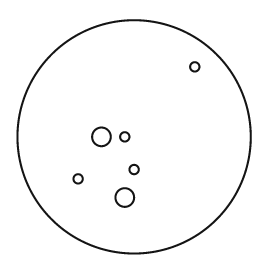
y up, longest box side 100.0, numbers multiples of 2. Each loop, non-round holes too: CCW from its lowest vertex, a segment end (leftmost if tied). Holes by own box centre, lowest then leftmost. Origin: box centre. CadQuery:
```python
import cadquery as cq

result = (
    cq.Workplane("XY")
    .moveTo(0.0, 0.0)
    .circle(50.0)
    .moveTo(-4.0, -26.0)
    .circle(4.0)
    .moveTo(-24.0, -18.0)
    .circle(2.0)
    .moveTo(0.0, -14.0)
    .circle(2.0)
    .moveTo(-14.0, 0.0)
    .circle(4.0)
    .moveTo(-4.0, 0.0)
    .circle(2.0)
    .moveTo(26.0, 30.0)
    .circle(2.0)
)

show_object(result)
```